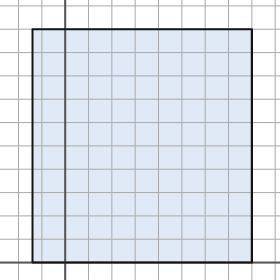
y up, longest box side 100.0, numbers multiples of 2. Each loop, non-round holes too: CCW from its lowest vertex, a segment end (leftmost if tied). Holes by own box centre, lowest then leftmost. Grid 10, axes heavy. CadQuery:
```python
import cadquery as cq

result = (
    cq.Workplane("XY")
    .moveTo(-14.0, 0.0)
    .lineTo(80.0, 0.0)
    .lineTo(80.0, 100.0)
    .lineTo(-14.0, 100.0)
    .close()
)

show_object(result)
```